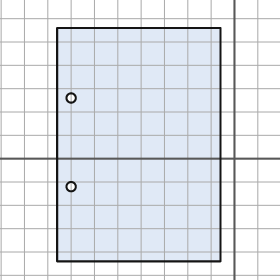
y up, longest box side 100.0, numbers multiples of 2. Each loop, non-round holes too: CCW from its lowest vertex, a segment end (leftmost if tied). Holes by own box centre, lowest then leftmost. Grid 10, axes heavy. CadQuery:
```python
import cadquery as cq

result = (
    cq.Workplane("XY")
    .moveTo(-76.0, -44.0)
    .lineTo(-6.0, -44.0)
    .lineTo(-6.0, 56.0)
    .lineTo(-76.0, 56.0)
    .close()
    .moveTo(-70.0, -12.0)
    .circle(2.0)
    .moveTo(-70.0, 26.0)
    .circle(2.0)
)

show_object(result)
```